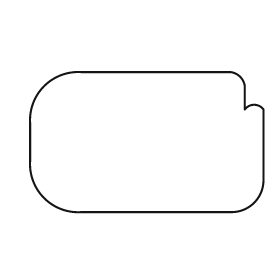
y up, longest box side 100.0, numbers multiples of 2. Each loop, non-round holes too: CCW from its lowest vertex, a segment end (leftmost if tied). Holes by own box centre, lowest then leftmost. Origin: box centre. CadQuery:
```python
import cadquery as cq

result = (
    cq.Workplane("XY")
    .moveTo(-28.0, -30.0)
    .lineTo(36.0, -30.0)
    .threePointArc((46.0, -26.0), (50.0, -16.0))
    .lineTo(50.0, 14.0)
    .threePointArc((46.0, 16.0), (42.0, 14.0))
    .lineTo(42.0, 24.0)
    .threePointArc((40.0, 28.0), (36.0, 30.0))
    .lineTo(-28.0, 30.0)
    .threePointArc((-44.0, 24.0), (-50.0, 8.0))
    .lineTo(-50.0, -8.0)
    .threePointArc((-44.0, -24.0), (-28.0, -30.0))
    .close()
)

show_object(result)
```